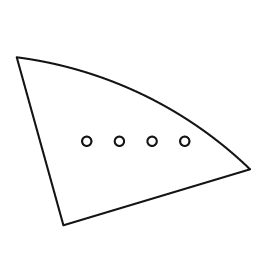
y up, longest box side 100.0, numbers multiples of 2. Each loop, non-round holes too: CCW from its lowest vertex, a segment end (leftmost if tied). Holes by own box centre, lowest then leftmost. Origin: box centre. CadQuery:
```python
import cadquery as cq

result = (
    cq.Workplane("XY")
    .moveTo(-30.0, -36.0)
    .lineTo(50.0, -12.0)
    .threePointArc((4.0, 20.0), (-50.0, 36.0))
    .close()
    .moveTo(-20.0, 0.0)
    .circle(2.0)
    .moveTo(-6.0, 0.0)
    .circle(2.0)
    .moveTo(8.0, 0.0)
    .circle(2.0)
    .moveTo(22.0, 0.0)
    .circle(2.0)
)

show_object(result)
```